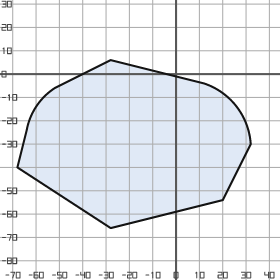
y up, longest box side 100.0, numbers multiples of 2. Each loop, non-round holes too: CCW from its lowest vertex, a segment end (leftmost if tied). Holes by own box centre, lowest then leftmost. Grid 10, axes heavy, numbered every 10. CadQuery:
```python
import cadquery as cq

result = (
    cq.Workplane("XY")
    .moveTo(-28.0, -66.0)
    .lineTo(20.0, -54.0)
    .lineTo(32.0, -30.0)
    .threePointArc((26.0, -14.0), (12.0, -4.0))
    .lineTo(-28.0, 6.0)
    .lineTo(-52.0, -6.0)
    .threePointArc((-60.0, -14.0), (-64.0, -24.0))
    .lineTo(-68.0, -40.0)
    .close()
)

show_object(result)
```